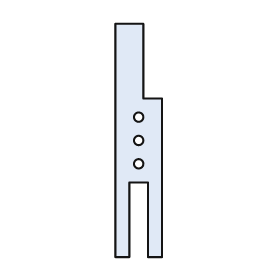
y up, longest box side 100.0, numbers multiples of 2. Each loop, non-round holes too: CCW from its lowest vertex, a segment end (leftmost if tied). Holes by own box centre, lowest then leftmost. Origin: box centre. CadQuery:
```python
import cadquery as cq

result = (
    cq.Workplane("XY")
    .moveTo(-10.0, -50.0)
    .lineTo(-4.0, -50.0)
    .lineTo(-4.0, -18.0)
    .lineTo(4.0, -18.0)
    .lineTo(4.0, -50.0)
    .lineTo(10.0, -50.0)
    .lineTo(10.0, 18.0)
    .lineTo(2.0, 18.0)
    .lineTo(2.0, 50.0)
    .lineTo(-10.0, 50.0)
    .close()
    .moveTo(0.0, -10.0)
    .circle(2.0)
    .moveTo(0.0, 0.0)
    .circle(2.0)
    .moveTo(0.0, 10.0)
    .circle(2.0)
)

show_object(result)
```